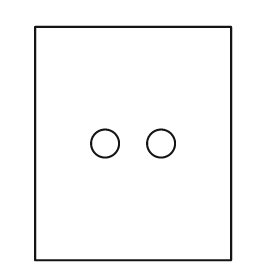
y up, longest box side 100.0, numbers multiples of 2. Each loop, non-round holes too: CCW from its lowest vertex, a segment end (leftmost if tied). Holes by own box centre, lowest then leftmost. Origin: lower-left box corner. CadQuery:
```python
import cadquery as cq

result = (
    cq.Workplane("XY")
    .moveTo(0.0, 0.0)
    .lineTo(84.0, 0.0)
    .lineTo(84.0, 100.0)
    .lineTo(0.0, 100.0)
    .close()
    .moveTo(30.0, 50.0)
    .circle(6.0)
    .moveTo(54.0, 50.0)
    .circle(6.0)
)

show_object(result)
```